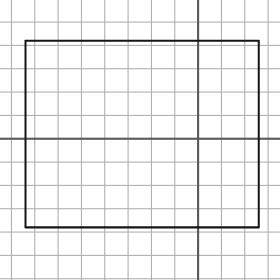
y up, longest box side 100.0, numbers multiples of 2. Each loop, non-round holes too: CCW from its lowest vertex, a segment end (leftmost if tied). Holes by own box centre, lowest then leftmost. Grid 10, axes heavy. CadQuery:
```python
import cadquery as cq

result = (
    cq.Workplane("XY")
    .moveTo(-74.0, -38.0)
    .lineTo(26.0, -38.0)
    .lineTo(26.0, 42.0)
    .lineTo(-74.0, 42.0)
    .close()
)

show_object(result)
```